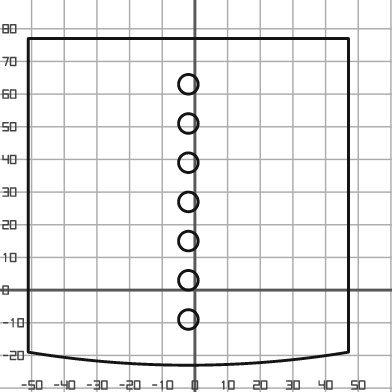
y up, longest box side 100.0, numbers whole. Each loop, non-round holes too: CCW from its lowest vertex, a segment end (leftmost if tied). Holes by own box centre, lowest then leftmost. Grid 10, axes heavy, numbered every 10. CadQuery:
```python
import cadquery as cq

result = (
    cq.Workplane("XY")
    .moveTo(-51.0, -19.0)
    .threePointArc((-2.0, -23.0), (47.0, -19.0))
    .lineTo(47.0, 77.0)
    .lineTo(-51.0, 77.0)
    .close()
    .moveTo(-2.0, -9.0)
    .circle(3.0)
    .moveTo(-2.0, 3.0)
    .circle(3.0)
    .moveTo(-2.0, 15.0)
    .circle(3.0)
    .moveTo(-2.0, 27.0)
    .circle(3.0)
    .moveTo(-2.0, 39.0)
    .circle(3.0)
    .moveTo(-2.0, 51.0)
    .circle(3.0)
    .moveTo(-2.0, 63.0)
    .circle(3.0)
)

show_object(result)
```